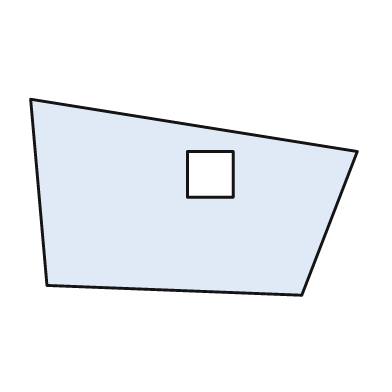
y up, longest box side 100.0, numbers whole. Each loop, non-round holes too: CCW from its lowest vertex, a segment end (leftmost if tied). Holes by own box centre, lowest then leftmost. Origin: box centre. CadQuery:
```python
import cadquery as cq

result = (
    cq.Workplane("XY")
    .moveTo(33.0, -30.0)
    .lineTo(50.0, 14.0)
    .lineTo(-50.0, 30.0)
    .lineTo(-45.0, -27.0)
    .close()
    .moveTo(-2.0, 0.0)
    .lineTo(12.0, 0.0)
    .lineTo(12.0, 14.0)
    .lineTo(-2.0, 14.0)
    .close()
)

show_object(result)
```